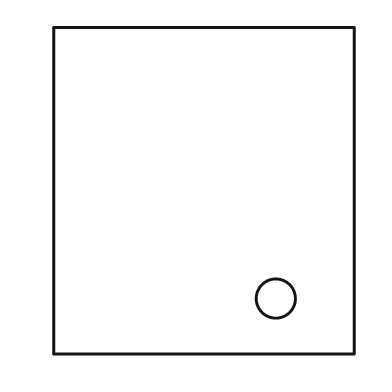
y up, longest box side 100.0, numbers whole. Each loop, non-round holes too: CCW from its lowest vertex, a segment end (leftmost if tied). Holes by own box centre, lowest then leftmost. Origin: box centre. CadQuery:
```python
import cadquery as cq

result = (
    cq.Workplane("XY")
    .moveTo(-46.0, -50.0)
    .lineTo(46.0, -50.0)
    .lineTo(46.0, 50.0)
    .lineTo(-46.0, 50.0)
    .close()
    .moveTo(22.0, -33.0)
    .circle(6.0)
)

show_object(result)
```